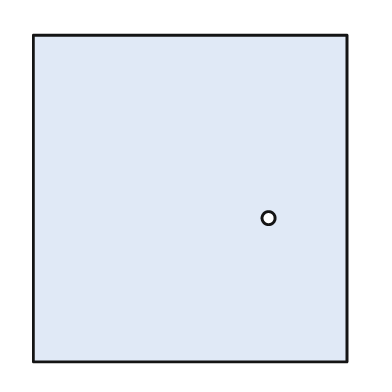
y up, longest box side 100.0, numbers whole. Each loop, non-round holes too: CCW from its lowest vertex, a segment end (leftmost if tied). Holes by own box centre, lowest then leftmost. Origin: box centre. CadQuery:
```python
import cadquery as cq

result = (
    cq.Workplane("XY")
    .moveTo(-48.0, -50.0)
    .lineTo(48.0, -50.0)
    .lineTo(48.0, 50.0)
    .lineTo(-48.0, 50.0)
    .close()
    .moveTo(24.0, -6.0)
    .circle(2.0)
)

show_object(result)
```